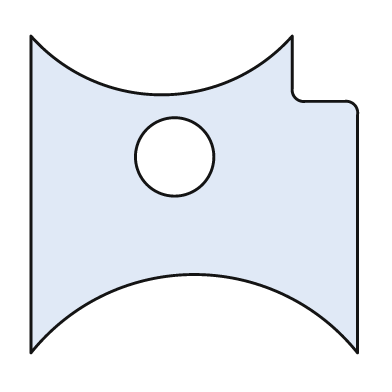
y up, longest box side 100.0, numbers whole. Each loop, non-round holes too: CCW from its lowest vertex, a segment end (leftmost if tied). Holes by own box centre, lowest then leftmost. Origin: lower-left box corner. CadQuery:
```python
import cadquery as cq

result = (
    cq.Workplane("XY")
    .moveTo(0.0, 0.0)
    .threePointArc((50.0, 24.0), (100.0, 0.0))
    .lineTo(100.0, 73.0)
    .threePointArc((99.0, 76.0), (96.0, 77.0))
    .lineTo(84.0, 77.0)
    .threePointArc((81.0, 78.0), (80.0, 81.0))
    .lineTo(80.0, 97.0)
    .threePointArc((40.0, 79.0), (0.0, 97.0))
    .close()
    .moveTo(44.0, 60.0)
    .circle(12.0)
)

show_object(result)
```